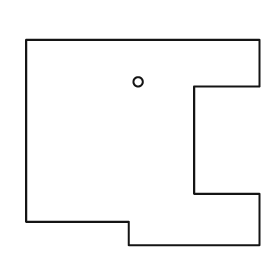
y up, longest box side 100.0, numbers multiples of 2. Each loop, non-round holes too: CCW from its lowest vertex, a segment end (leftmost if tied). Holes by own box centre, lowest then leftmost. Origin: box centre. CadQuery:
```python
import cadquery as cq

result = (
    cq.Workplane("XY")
    .moveTo(-6.0, -44.0)
    .lineTo(50.0, -44.0)
    .lineTo(50.0, -22.0)
    .lineTo(22.0, -22.0)
    .lineTo(22.0, 24.0)
    .lineTo(50.0, 24.0)
    .lineTo(50.0, 44.0)
    .lineTo(-50.0, 44.0)
    .lineTo(-50.0, -34.0)
    .lineTo(-6.0, -34.0)
    .close()
    .moveTo(-2.0, 26.0)
    .circle(2.0)
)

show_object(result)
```